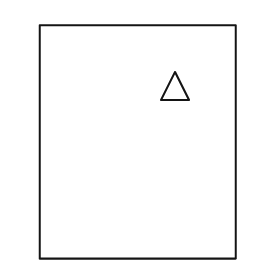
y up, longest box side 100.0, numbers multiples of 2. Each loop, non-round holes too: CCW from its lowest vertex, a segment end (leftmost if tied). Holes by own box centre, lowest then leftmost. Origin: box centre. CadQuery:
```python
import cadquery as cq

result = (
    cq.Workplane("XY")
    .moveTo(-42.0, -50.0)
    .lineTo(42.0, -50.0)
    .lineTo(42.0, 50.0)
    .lineTo(-42.0, 50.0)
    .close()
    .moveTo(10.0, 18.0)
    .lineTo(22.0, 18.0)
    .lineTo(16.0, 30.0)
    .close()
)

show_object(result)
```